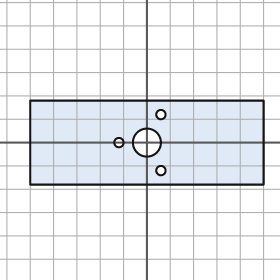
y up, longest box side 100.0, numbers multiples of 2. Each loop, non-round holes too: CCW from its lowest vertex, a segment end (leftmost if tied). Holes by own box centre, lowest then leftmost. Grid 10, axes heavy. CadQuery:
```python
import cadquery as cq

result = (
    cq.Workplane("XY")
    .moveTo(-50.0, -18.0)
    .lineTo(50.0, -18.0)
    .lineTo(50.0, 18.0)
    .lineTo(-50.0, 18.0)
    .close()
    .moveTo(6.0, -12.0)
    .circle(2.0)
    .moveTo(-12.0, 0.0)
    .circle(2.0)
    .moveTo(0.0, 0.0)
    .circle(6.0)
    .moveTo(6.0, 12.0)
    .circle(2.0)
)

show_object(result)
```